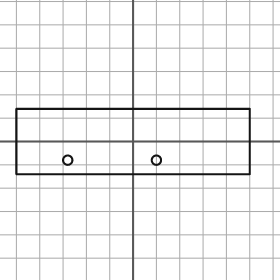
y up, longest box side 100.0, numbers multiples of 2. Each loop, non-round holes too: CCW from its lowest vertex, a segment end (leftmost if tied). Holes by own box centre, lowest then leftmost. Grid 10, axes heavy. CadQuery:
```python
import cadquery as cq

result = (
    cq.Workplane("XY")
    .moveTo(-50.0, -14.0)
    .lineTo(50.0, -14.0)
    .lineTo(50.0, 14.0)
    .lineTo(-50.0, 14.0)
    .close()
    .moveTo(-28.0, -8.0)
    .circle(2.0)
    .moveTo(10.0, -8.0)
    .circle(2.0)
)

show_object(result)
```